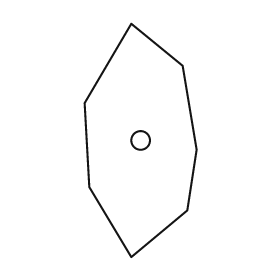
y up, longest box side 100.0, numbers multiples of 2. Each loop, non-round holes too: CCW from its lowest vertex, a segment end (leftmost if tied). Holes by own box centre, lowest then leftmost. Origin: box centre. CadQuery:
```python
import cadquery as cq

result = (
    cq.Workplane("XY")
    .moveTo(-4.0, -50.0)
    .lineTo(20.0, -30.0)
    .lineTo(24.0, -4.0)
    .lineTo(18.0, 32.0)
    .lineTo(-4.0, 50.0)
    .lineTo(-24.0, 16.0)
    .lineTo(-22.0, -20.0)
    .close()
    .moveTo(0.0, 0.0)
    .circle(4.0)
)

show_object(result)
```